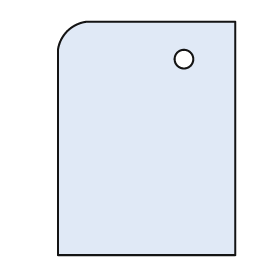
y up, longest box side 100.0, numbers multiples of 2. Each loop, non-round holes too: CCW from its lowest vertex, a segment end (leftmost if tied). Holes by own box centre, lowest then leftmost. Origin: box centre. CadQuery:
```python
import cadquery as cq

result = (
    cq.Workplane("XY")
    .moveTo(-38.0, -50.0)
    .lineTo(38.0, -50.0)
    .lineTo(38.0, 50.0)
    .lineTo(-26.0, 50.0)
    .threePointArc((-34.0, 46.0), (-38.0, 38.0))
    .close()
    .moveTo(16.0, 34.0)
    .circle(4.0)
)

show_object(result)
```